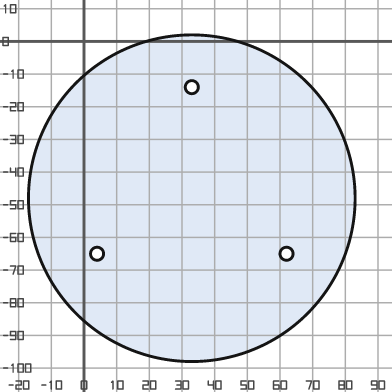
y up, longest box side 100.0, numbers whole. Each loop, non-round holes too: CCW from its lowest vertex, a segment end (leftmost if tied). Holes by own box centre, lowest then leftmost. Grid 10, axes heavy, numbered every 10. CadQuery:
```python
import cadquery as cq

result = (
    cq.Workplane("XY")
    .moveTo(33.0, -48.0)
    .circle(50.0)
    .moveTo(4.0, -65.0)
    .circle(2.0)
    .moveTo(62.0, -65.0)
    .circle(2.0)
    .moveTo(33.0, -14.0)
    .circle(2.0)
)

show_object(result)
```